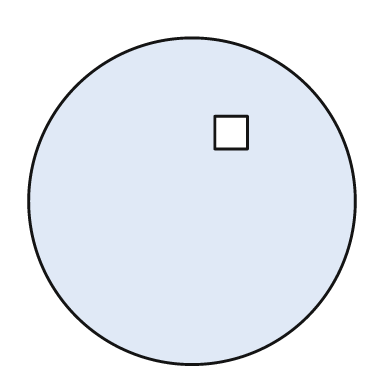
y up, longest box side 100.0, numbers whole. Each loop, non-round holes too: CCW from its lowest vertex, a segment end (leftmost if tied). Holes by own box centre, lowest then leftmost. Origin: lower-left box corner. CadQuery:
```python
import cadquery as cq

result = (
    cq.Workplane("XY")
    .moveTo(50.0, 50.0)
    .circle(50.0)
    .moveTo(57.0, 66.0)
    .lineTo(67.0, 66.0)
    .lineTo(67.0, 76.0)
    .lineTo(57.0, 76.0)
    .close()
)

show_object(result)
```